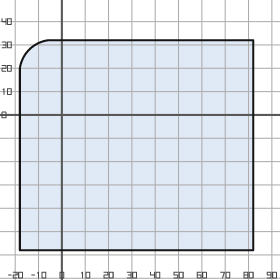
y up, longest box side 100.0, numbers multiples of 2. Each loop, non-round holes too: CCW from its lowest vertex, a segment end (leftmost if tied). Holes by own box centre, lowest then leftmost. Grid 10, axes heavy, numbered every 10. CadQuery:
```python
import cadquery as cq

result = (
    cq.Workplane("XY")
    .moveTo(-18.0, -58.0)
    .lineTo(82.0, -58.0)
    .lineTo(82.0, 32.0)
    .lineTo(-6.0, 32.0)
    .threePointArc((-14.0, 28.0), (-18.0, 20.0))
    .close()
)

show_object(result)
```